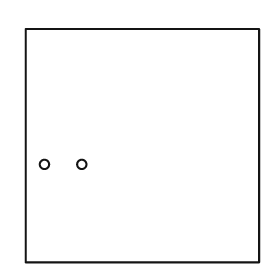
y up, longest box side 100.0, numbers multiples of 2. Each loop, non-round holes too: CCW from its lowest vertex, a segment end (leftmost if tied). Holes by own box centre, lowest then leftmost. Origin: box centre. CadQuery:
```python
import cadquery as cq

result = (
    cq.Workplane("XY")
    .moveTo(-50.0, -50.0)
    .lineTo(50.0, -50.0)
    .lineTo(50.0, 50.0)
    .lineTo(-50.0, 50.0)
    .close()
    .moveTo(-42.0, -8.0)
    .circle(2.0)
    .moveTo(-26.0, -8.0)
    .circle(2.0)
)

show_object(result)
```